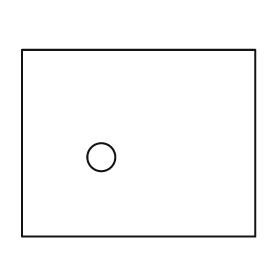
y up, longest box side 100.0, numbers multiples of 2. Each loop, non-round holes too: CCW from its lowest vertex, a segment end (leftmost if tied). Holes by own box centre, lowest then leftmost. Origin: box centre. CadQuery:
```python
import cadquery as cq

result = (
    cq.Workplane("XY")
    .moveTo(-50.0, -40.0)
    .lineTo(50.0, -40.0)
    .lineTo(50.0, 40.0)
    .lineTo(-50.0, 40.0)
    .close()
    .moveTo(-16.0, -6.0)
    .circle(6.0)
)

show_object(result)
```